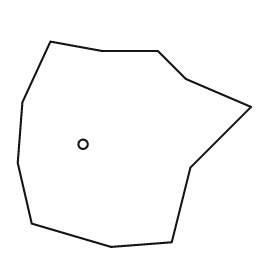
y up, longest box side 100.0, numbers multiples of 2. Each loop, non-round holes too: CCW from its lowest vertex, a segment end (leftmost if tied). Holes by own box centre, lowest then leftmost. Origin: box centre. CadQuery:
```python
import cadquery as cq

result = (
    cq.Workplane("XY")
    .moveTo(-10.0, -44.0)
    .lineTo(16.0, -42.0)
    .lineTo(24.0, -10.0)
    .lineTo(50.0, 16.0)
    .lineTo(22.0, 28.0)
    .lineTo(10.0, 40.0)
    .lineTo(-14.0, 40.0)
    .lineTo(-36.0, 44.0)
    .lineTo(-48.0, 18.0)
    .lineTo(-50.0, -8.0)
    .lineTo(-44.0, -34.0)
    .close()
    .moveTo(-22.0, 0.0)
    .circle(2.0)
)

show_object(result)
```